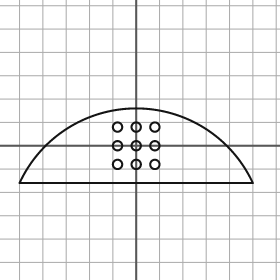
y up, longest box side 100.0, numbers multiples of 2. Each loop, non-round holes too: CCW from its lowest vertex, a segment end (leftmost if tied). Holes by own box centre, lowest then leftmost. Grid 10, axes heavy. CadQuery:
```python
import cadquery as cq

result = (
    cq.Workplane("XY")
    .moveTo(-50.0, -16.0)
    .lineTo(50.0, -16.0)
    .threePointArc((0.0, 16.0), (-50.0, -16.0))
    .close()
    .moveTo(-8.0, -8.0)
    .circle(2.0)
    .moveTo(0.0, -8.0)
    .circle(2.0)
    .moveTo(8.0, -8.0)
    .circle(2.0)
    .moveTo(-8.0, 0.0)
    .circle(2.0)
    .moveTo(0.0, 0.0)
    .circle(2.0)
    .moveTo(8.0, 0.0)
    .circle(2.0)
    .moveTo(-8.0, 8.0)
    .circle(2.0)
    .moveTo(0.0, 8.0)
    .circle(2.0)
    .moveTo(8.0, 8.0)
    .circle(2.0)
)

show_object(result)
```